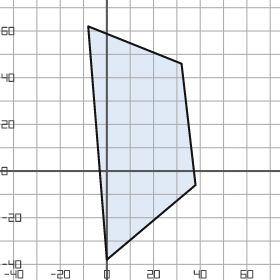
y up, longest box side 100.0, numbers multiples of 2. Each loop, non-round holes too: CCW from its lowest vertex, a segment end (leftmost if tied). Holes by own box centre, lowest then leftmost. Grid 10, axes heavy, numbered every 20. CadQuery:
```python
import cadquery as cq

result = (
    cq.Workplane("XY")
    .moveTo(0.0, -38.0)
    .lineTo(38.0, -6.0)
    .lineTo(32.0, 46.0)
    .lineTo(-8.0, 62.0)
    .close()
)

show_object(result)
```